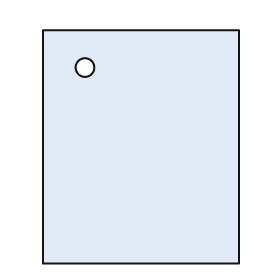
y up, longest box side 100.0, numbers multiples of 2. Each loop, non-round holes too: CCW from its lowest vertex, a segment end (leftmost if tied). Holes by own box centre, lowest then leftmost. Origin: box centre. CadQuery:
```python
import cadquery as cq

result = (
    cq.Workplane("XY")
    .moveTo(-42.0, -50.0)
    .lineTo(42.0, -50.0)
    .lineTo(42.0, 50.0)
    .lineTo(-42.0, 50.0)
    .close()
    .moveTo(-24.0, 34.0)
    .circle(4.0)
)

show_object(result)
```